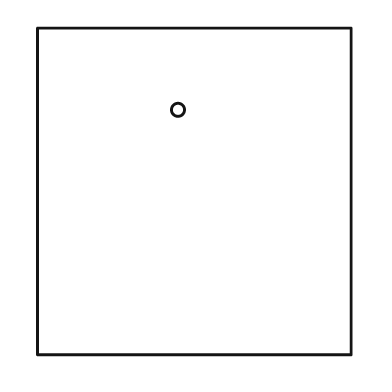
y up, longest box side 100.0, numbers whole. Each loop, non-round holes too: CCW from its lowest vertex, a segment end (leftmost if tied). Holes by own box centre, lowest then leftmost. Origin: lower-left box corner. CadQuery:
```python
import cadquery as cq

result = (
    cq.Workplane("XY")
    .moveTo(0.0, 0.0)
    .lineTo(96.0, 0.0)
    .lineTo(96.0, 100.0)
    .lineTo(0.0, 100.0)
    .close()
    .moveTo(43.0, 75.0)
    .circle(2.0)
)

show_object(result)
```